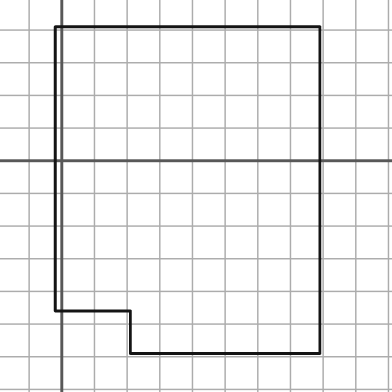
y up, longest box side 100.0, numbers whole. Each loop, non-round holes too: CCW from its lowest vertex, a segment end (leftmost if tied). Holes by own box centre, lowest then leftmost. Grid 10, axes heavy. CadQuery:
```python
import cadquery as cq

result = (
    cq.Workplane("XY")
    .moveTo(21.0, -59.0)
    .lineTo(79.0, -59.0)
    .lineTo(79.0, 41.0)
    .lineTo(-2.0, 41.0)
    .lineTo(-2.0, -46.0)
    .lineTo(21.0, -46.0)
    .close()
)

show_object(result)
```